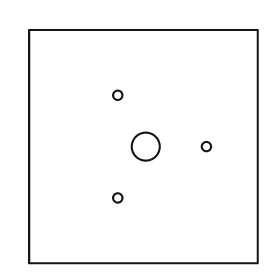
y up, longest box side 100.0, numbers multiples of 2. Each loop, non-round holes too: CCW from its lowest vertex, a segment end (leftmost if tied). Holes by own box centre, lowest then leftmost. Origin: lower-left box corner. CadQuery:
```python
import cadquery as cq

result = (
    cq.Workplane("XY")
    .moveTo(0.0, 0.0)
    .lineTo(98.0, 0.0)
    .lineTo(98.0, 100.0)
    .lineTo(0.0, 100.0)
    .close()
    .moveTo(38.0, 28.0)
    .circle(2.0)
    .moveTo(50.0, 50.0)
    .circle(6.0)
    .moveTo(76.0, 50.0)
    .circle(2.0)
    .moveTo(38.0, 72.0)
    .circle(2.0)
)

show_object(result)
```